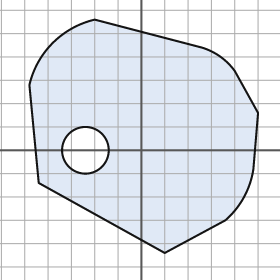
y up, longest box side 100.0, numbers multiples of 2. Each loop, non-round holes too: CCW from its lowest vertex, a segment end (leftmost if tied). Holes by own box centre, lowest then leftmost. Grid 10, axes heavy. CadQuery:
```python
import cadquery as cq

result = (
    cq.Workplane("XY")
    .moveTo(10.0, -44.0)
    .lineTo(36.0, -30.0)
    .threePointArc((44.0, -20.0), (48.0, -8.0))
    .lineTo(50.0, 16.0)
    .lineTo(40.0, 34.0)
    .threePointArc((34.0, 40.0), (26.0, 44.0))
    .lineTo(-20.0, 56.0)
    .threePointArc((-38.0, 46.0), (-48.0, 28.0))
    .lineTo(-44.0, -14.0)
    .close()
    .moveTo(-24.0, 0.0)
    .circle(10.0)
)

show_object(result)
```